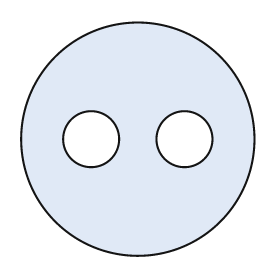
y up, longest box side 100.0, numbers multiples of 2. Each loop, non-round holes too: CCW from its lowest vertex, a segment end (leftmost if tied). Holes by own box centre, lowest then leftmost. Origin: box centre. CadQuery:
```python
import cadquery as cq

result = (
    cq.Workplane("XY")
    .moveTo(0.0, 0.0)
    .circle(50.0)
    .moveTo(-20.0, 0.0)
    .circle(12.0)
    .moveTo(20.0, 0.0)
    .circle(12.0)
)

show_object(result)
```